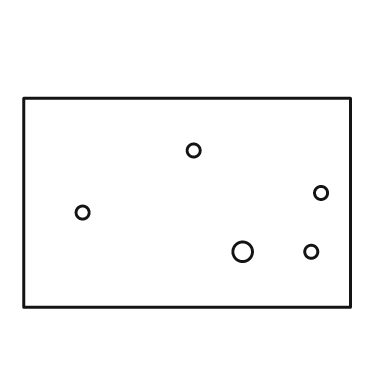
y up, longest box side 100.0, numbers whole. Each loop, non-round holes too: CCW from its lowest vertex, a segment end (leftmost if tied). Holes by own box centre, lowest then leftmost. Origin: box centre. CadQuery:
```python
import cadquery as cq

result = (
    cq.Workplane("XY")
    .moveTo(-50.0, -32.0)
    .lineTo(50.0, -32.0)
    .lineTo(50.0, 32.0)
    .lineTo(-50.0, 32.0)
    .close()
    .moveTo(17.0, -15.0)
    .circle(3.0)
    .moveTo(38.0, -15.0)
    .circle(2.0)
    .moveTo(-32.0, -3.0)
    .circle(2.0)
    .moveTo(41.0, 3.0)
    .circle(2.0)
    .moveTo(2.0, 16.0)
    .circle(2.0)
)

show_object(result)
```